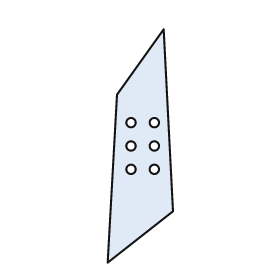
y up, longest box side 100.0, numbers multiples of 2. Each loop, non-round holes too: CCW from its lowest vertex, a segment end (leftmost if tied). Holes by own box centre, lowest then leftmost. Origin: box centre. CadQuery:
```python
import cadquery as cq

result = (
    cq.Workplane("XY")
    .moveTo(-14.0, -50.0)
    .lineTo(14.0, -28.0)
    .lineTo(10.0, 50.0)
    .lineTo(-10.0, 22.0)
    .close()
    .moveTo(-4.0, -10.0)
    .circle(2.0)
    .moveTo(6.0, -10.0)
    .circle(2.0)
    .moveTo(-4.0, 0.0)
    .circle(2.0)
    .moveTo(6.0, 0.0)
    .circle(2.0)
    .moveTo(-4.0, 10.0)
    .circle(2.0)
    .moveTo(6.0, 10.0)
    .circle(2.0)
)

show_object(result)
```